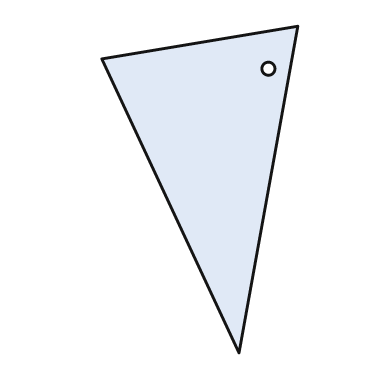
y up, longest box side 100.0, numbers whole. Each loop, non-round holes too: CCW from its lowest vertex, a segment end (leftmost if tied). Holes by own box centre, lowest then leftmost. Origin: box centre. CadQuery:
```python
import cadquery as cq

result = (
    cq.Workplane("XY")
    .moveTo(12.0, -50.0)
    .lineTo(30.0, 50.0)
    .lineTo(-30.0, 40.0)
    .close()
    .moveTo(21.0, 37.0)
    .circle(2.0)
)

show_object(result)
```